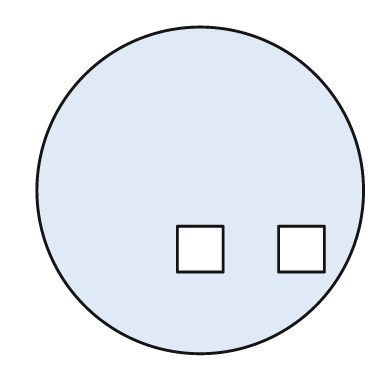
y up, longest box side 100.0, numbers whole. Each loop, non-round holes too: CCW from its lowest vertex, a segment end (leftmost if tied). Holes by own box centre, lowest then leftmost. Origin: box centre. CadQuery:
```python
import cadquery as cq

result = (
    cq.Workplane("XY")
    .moveTo(0.0, 0.0)
    .circle(50.0)
    .moveTo(-7.0, -25.0)
    .lineTo(7.0, -25.0)
    .lineTo(7.0, -11.0)
    .lineTo(-7.0, -11.0)
    .close()
    .moveTo(24.0, -25.0)
    .lineTo(38.0, -25.0)
    .lineTo(38.0, -11.0)
    .lineTo(24.0, -11.0)
    .close()
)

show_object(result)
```